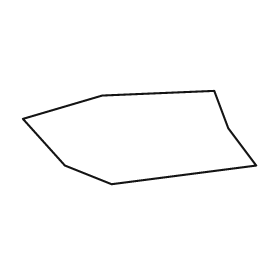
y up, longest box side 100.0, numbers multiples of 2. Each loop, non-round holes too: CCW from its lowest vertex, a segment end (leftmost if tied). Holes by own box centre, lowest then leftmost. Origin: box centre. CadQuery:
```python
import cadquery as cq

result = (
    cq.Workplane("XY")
    .moveTo(-12.0, -20.0)
    .lineTo(50.0, -12.0)
    .lineTo(38.0, 4.0)
    .lineTo(32.0, 20.0)
    .lineTo(-16.0, 18.0)
    .lineTo(-50.0, 8.0)
    .lineTo(-32.0, -12.0)
    .close()
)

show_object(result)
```